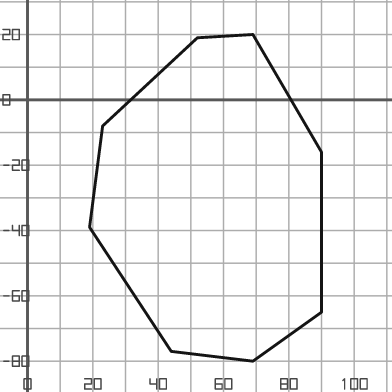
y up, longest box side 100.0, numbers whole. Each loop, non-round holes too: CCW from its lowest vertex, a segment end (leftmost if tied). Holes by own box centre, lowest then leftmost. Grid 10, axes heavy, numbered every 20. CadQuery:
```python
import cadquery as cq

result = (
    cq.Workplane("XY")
    .moveTo(69.0, -80.0)
    .lineTo(90.0, -65.0)
    .lineTo(90.0, -16.0)
    .lineTo(69.0, 20.0)
    .lineTo(52.0, 19.0)
    .lineTo(23.0, -8.0)
    .lineTo(19.0, -39.0)
    .lineTo(44.0, -77.0)
    .close()
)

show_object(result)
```